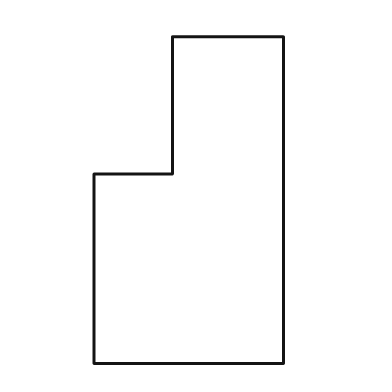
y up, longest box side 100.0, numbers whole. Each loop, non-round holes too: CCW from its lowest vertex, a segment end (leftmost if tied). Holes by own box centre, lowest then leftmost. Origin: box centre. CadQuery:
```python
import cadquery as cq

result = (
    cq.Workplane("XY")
    .moveTo(-29.0, -50.0)
    .lineTo(29.0, -50.0)
    .lineTo(29.0, 50.0)
    .lineTo(-5.0, 50.0)
    .lineTo(-5.0, 8.0)
    .lineTo(-29.0, 8.0)
    .close()
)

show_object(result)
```